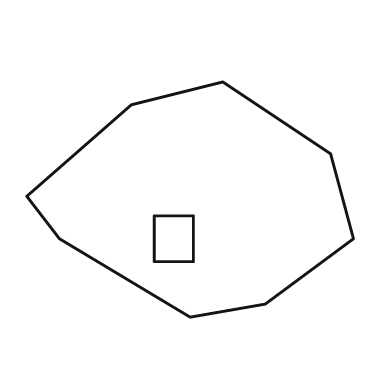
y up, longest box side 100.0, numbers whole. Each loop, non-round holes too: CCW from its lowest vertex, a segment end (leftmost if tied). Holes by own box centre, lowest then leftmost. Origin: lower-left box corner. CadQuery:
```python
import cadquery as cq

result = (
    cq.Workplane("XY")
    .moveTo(50.0, 0.0)
    .lineTo(73.0, 4.0)
    .lineTo(100.0, 24.0)
    .lineTo(93.0, 50.0)
    .lineTo(60.0, 72.0)
    .lineTo(32.0, 65.0)
    .lineTo(0.0, 37.0)
    .lineTo(10.0, 24.0)
    .close()
    .moveTo(39.0, 17.0)
    .lineTo(51.0, 17.0)
    .lineTo(51.0, 31.0)
    .lineTo(39.0, 31.0)
    .close()
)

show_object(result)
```